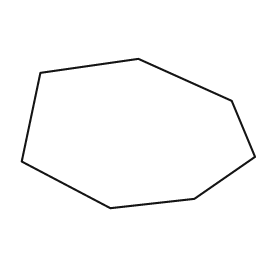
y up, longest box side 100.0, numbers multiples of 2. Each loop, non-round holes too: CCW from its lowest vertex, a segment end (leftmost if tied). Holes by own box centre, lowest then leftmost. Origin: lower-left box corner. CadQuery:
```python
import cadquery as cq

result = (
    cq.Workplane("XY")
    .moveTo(38.0, 0.0)
    .lineTo(74.0, 4.0)
    .lineTo(100.0, 22.0)
    .lineTo(90.0, 46.0)
    .lineTo(50.0, 64.0)
    .lineTo(8.0, 58.0)
    .lineTo(0.0, 20.0)
    .close()
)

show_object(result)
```